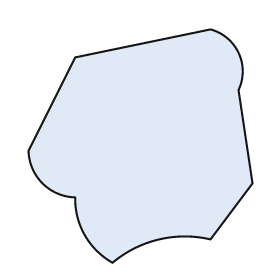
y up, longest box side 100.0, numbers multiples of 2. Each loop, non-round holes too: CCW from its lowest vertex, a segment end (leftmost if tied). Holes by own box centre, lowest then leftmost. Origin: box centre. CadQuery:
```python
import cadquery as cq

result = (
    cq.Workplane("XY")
    .moveTo(-12.0, -50.0)
    .threePointArc((8.0, -40.0), (30.0, -40.0))
    .lineTo(48.0, -16.0)
    .lineTo(42.0, 24.0)
    .threePointArc((42.0, 40.0), (30.0, 50.0))
    .lineTo(-28.0, 38.0)
    .lineTo(-48.0, -2.0)
    .threePointArc((-42.0, -16.0), (-28.0, -22.0))
    .threePointArc((-24.0, -38.0), (-12.0, -50.0))
    .close()
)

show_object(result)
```